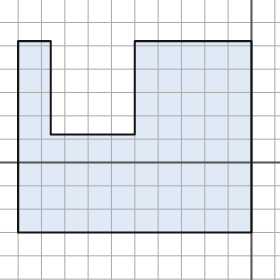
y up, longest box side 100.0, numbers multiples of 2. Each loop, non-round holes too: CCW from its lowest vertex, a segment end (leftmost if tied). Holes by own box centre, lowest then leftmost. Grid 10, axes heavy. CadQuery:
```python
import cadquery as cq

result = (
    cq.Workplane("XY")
    .moveTo(-100.0, -30.0)
    .lineTo(0.0, -30.0)
    .lineTo(0.0, 52.0)
    .lineTo(-50.0, 52.0)
    .lineTo(-50.0, 12.0)
    .lineTo(-86.0, 12.0)
    .lineTo(-86.0, 52.0)
    .lineTo(-100.0, 52.0)
    .close()
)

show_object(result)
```